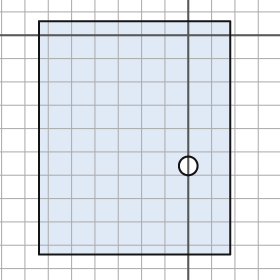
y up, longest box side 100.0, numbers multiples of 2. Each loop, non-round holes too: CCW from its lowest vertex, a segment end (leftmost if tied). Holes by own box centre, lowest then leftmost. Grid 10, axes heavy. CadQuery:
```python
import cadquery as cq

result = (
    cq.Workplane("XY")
    .moveTo(-64.0, -94.0)
    .lineTo(18.0, -94.0)
    .lineTo(18.0, 6.0)
    .lineTo(-64.0, 6.0)
    .close()
    .moveTo(0.0, -56.0)
    .circle(4.0)
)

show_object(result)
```